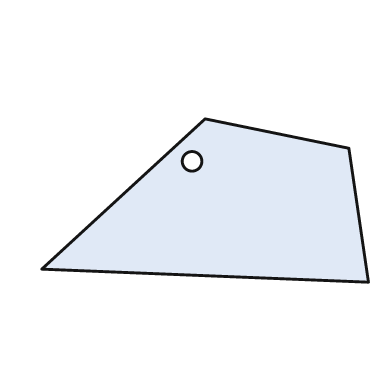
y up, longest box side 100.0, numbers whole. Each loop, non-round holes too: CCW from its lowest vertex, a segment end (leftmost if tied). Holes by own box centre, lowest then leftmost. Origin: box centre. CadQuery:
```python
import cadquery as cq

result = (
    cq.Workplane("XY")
    .moveTo(50.0, -25.0)
    .lineTo(44.0, 16.0)
    .lineTo(0.0, 25.0)
    .lineTo(-50.0, -21.0)
    .close()
    .moveTo(-4.0, 12.0)
    .circle(3.0)
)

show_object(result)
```